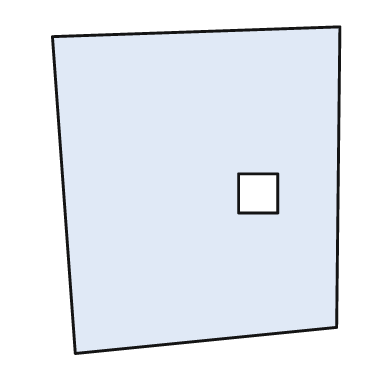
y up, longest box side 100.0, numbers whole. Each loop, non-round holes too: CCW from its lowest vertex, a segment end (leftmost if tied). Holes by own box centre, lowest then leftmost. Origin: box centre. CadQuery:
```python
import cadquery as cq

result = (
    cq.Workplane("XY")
    .moveTo(-37.0, -50.0)
    .lineTo(43.0, -42.0)
    .lineTo(44.0, 50.0)
    .lineTo(-44.0, 47.0)
    .close()
    .moveTo(13.0, -7.0)
    .lineTo(25.0, -7.0)
    .lineTo(25.0, 5.0)
    .lineTo(13.0, 5.0)
    .close()
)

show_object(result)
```